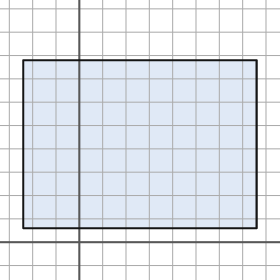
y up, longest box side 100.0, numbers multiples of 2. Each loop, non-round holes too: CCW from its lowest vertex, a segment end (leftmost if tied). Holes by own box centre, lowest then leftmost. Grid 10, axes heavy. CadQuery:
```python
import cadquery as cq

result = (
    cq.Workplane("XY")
    .moveTo(-24.0, 6.0)
    .lineTo(76.0, 6.0)
    .lineTo(76.0, 78.0)
    .lineTo(-24.0, 78.0)
    .close()
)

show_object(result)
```